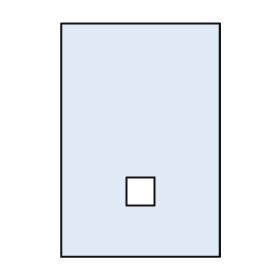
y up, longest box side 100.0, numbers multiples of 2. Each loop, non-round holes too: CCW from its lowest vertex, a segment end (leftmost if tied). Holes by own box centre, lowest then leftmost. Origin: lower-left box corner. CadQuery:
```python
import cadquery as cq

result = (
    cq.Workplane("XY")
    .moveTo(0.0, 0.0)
    .lineTo(68.0, 0.0)
    .lineTo(68.0, 100.0)
    .lineTo(0.0, 100.0)
    .close()
    .moveTo(28.0, 22.0)
    .lineTo(40.0, 22.0)
    .lineTo(40.0, 34.0)
    .lineTo(28.0, 34.0)
    .close()
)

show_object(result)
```